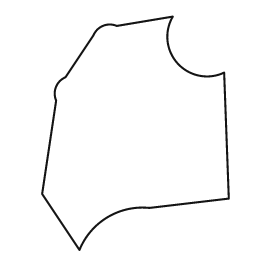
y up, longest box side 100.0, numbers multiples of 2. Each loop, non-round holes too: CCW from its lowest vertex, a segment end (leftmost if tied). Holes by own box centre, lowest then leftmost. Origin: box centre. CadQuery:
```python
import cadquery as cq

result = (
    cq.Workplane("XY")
    .moveTo(-24.0, -50.0)
    .threePointArc((-12.0, -36.0), (6.0, -32.0))
    .lineTo(40.0, -28.0)
    .lineTo(38.0, 26.0)
    .threePointArc((18.0, 30.0), (16.0, 50.0))
    .lineTo(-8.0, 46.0)
    .threePointArc((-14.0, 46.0), (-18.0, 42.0))
    .lineTo(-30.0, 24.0)
    .threePointArc((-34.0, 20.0), (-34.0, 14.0))
    .lineTo(-40.0, -26.0)
    .close()
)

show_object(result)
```